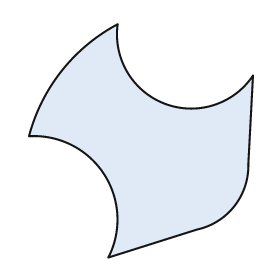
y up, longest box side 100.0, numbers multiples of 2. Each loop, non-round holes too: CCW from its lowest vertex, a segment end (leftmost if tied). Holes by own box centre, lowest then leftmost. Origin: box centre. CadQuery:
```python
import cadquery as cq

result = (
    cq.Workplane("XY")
    .moveTo(-14.0, -50.0)
    .lineTo(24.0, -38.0)
    .threePointArc((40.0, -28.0), (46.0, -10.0))
    .lineTo(48.0, 28.0)
    .threePointArc((10.0, 16.0), (-10.0, 50.0))
    .threePointArc((-34.0, 30.0), (-48.0, 2.0))
    .threePointArc((-16.0, -14.0), (-14.0, -50.0))
    .close()
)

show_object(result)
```